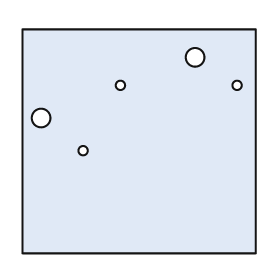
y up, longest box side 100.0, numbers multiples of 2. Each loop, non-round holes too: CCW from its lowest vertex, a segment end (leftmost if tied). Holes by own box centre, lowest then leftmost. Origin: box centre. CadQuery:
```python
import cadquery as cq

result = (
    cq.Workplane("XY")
    .moveTo(-50.0, -48.0)
    .lineTo(50.0, -48.0)
    .lineTo(50.0, 48.0)
    .lineTo(-50.0, 48.0)
    .close()
    .moveTo(-24.0, -4.0)
    .circle(2.0)
    .moveTo(-42.0, 10.0)
    .circle(4.0)
    .moveTo(-8.0, 24.0)
    .circle(2.0)
    .moveTo(42.0, 24.0)
    .circle(2.0)
    .moveTo(24.0, 36.0)
    .circle(4.0)
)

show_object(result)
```